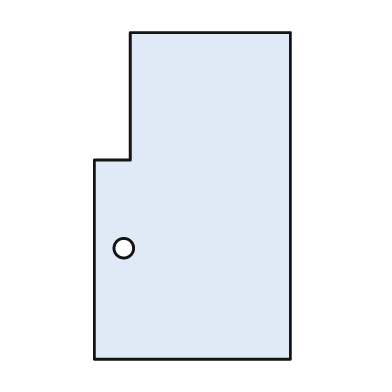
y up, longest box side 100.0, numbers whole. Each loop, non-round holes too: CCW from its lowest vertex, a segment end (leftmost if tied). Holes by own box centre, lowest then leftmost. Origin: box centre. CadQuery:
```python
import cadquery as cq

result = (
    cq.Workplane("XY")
    .moveTo(-30.0, -50.0)
    .lineTo(30.0, -50.0)
    .lineTo(30.0, 50.0)
    .lineTo(-19.0, 50.0)
    .lineTo(-19.0, 11.0)
    .lineTo(-30.0, 11.0)
    .close()
    .moveTo(-21.0, -16.0)
    .circle(3.0)
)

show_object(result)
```